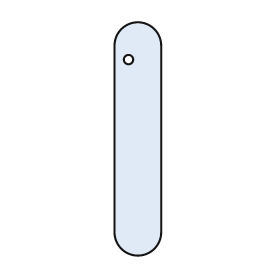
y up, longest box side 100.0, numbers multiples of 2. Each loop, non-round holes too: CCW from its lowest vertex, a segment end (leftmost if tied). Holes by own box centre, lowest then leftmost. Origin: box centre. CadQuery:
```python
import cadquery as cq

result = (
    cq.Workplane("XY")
    .moveTo(-10.0, -40.0)
    .threePointArc((0.0, -50.0), (10.0, -40.0))
    .lineTo(10.0, 40.0)
    .threePointArc((0.0, 50.0), (-10.0, 40.0))
    .close()
    .moveTo(-4.0, 34.0)
    .circle(2.0)
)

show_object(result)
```